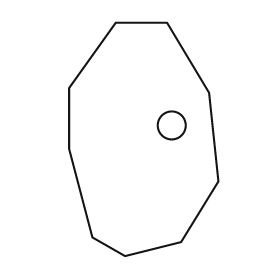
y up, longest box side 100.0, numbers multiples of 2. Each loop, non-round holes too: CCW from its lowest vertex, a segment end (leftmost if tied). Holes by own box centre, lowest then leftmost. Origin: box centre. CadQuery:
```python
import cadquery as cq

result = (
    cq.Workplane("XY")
    .moveTo(-8.0, -50.0)
    .lineTo(16.0, -44.0)
    .lineTo(32.0, -18.0)
    .lineTo(28.0, 20.0)
    .lineTo(10.0, 50.0)
    .lineTo(-12.0, 50.0)
    .lineTo(-32.0, 22.0)
    .lineTo(-32.0, -4.0)
    .lineTo(-22.0, -42.0)
    .close()
    .moveTo(12.0, 6.0)
    .circle(6.0)
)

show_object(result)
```